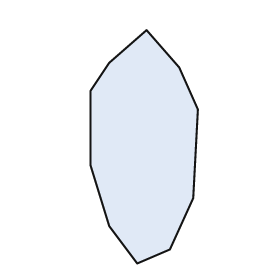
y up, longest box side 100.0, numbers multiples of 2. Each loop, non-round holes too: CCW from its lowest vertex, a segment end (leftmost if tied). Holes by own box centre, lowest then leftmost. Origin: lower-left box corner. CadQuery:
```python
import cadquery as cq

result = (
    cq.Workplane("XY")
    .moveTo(20.0, 0.0)
    .lineTo(34.0, 6.0)
    .lineTo(44.0, 28.0)
    .lineTo(46.0, 66.0)
    .lineTo(38.0, 84.0)
    .lineTo(24.0, 100.0)
    .lineTo(8.0, 86.0)
    .lineTo(0.0, 74.0)
    .lineTo(0.0, 42.0)
    .lineTo(8.0, 16.0)
    .close()
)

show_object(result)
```